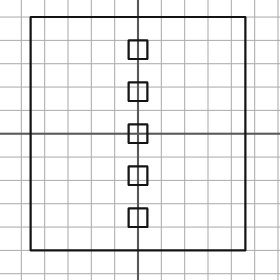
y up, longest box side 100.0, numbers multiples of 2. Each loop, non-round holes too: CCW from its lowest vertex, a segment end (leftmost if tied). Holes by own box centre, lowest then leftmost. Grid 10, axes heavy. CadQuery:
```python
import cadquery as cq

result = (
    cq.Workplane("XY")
    .moveTo(-46.0, -50.0)
    .lineTo(46.0, -50.0)
    .lineTo(46.0, 50.0)
    .lineTo(-46.0, 50.0)
    .close()
    .moveTo(-4.0, -40.0)
    .lineTo(4.0, -40.0)
    .lineTo(4.0, -32.0)
    .lineTo(-4.0, -32.0)
    .close()
    .moveTo(-4.0, -22.0)
    .lineTo(4.0, -22.0)
    .lineTo(4.0, -14.0)
    .lineTo(-4.0, -14.0)
    .close()
    .moveTo(-4.0, -4.0)
    .lineTo(4.0, -4.0)
    .lineTo(4.0, 4.0)
    .lineTo(-4.0, 4.0)
    .close()
    .moveTo(-4.0, 14.0)
    .lineTo(4.0, 14.0)
    .lineTo(4.0, 22.0)
    .lineTo(-4.0, 22.0)
    .close()
    .moveTo(-4.0, 32.0)
    .lineTo(4.0, 32.0)
    .lineTo(4.0, 40.0)
    .lineTo(-4.0, 40.0)
    .close()
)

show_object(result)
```